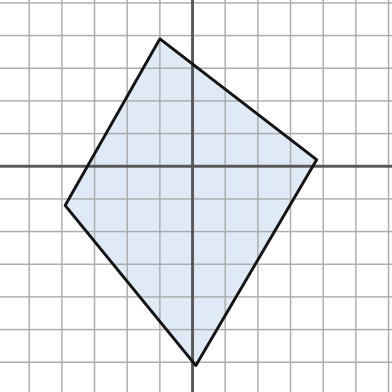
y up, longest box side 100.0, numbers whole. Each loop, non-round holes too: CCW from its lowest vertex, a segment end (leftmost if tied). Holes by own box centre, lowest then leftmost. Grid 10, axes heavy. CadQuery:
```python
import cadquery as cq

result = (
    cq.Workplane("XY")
    .moveTo(1.0, -61.0)
    .lineTo(38.0, 2.0)
    .lineTo(-10.0, 39.0)
    .lineTo(-39.0, -12.0)
    .close()
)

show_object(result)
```